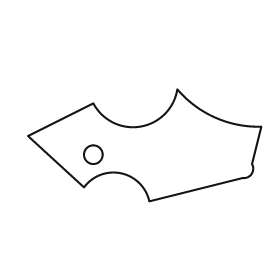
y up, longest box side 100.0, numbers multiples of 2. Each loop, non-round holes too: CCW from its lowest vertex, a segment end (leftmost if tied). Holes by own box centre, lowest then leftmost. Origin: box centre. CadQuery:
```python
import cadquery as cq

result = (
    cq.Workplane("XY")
    .moveTo(2.0, -24.0)
    .lineTo(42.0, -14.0)
    .threePointArc((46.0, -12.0), (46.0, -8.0))
    .lineTo(50.0, 8.0)
    .threePointArc((30.0, 12.0), (14.0, 24.0))
    .threePointArc((-2.0, 8.0), (-22.0, 18.0))
    .lineTo(-50.0, 4.0)
    .lineTo(-26.0, -18.0)
    .threePointArc((-10.0, -12.0), (2.0, -24.0))
    .close()
    .moveTo(-22.0, -4.0)
    .circle(4.0)
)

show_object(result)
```